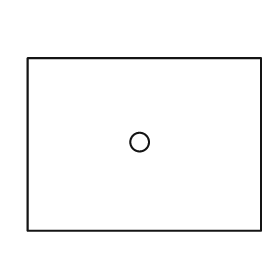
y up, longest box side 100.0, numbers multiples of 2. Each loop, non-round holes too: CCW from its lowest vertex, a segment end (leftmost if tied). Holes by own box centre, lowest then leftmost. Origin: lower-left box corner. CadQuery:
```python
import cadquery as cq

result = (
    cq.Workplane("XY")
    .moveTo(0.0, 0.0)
    .lineTo(100.0, 0.0)
    .lineTo(100.0, 74.0)
    .lineTo(0.0, 74.0)
    .close()
    .moveTo(48.0, 38.0)
    .circle(4.0)
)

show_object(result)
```